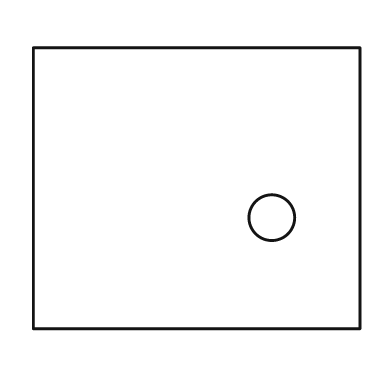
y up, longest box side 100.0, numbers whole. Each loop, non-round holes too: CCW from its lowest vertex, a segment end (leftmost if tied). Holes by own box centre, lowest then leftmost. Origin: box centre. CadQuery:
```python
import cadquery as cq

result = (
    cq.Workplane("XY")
    .moveTo(-50.0, -43.0)
    .lineTo(50.0, -43.0)
    .lineTo(50.0, 43.0)
    .lineTo(-50.0, 43.0)
    .close()
    .moveTo(23.0, -9.0)
    .circle(7.0)
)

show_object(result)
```